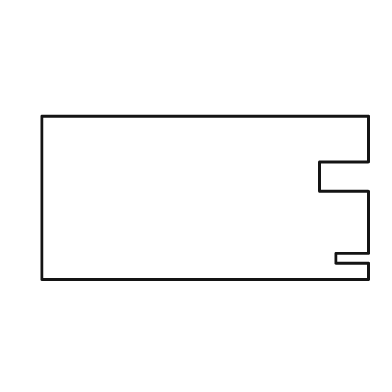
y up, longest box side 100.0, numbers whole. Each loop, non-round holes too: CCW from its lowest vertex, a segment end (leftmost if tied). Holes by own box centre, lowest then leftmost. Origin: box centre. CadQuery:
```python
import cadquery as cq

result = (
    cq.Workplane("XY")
    .moveTo(-50.0, -25.0)
    .lineTo(50.0, -25.0)
    .lineTo(50.0, -20.0)
    .lineTo(40.0, -20.0)
    .lineTo(40.0, -17.0)
    .lineTo(50.0, -17.0)
    .lineTo(50.0, 2.0)
    .lineTo(35.0, 2.0)
    .lineTo(35.0, 11.0)
    .lineTo(50.0, 11.0)
    .lineTo(50.0, 25.0)
    .lineTo(-50.0, 25.0)
    .close()
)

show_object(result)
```